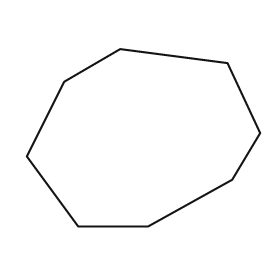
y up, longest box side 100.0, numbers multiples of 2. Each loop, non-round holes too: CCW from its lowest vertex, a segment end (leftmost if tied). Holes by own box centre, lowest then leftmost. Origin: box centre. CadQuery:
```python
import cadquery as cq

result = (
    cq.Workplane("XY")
    .moveTo(-28.0, -38.0)
    .lineTo(2.0, -38.0)
    .lineTo(38.0, -18.0)
    .lineTo(50.0, 2.0)
    .lineTo(36.0, 32.0)
    .lineTo(-10.0, 38.0)
    .lineTo(-34.0, 24.0)
    .lineTo(-50.0, -8.0)
    .close()
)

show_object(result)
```